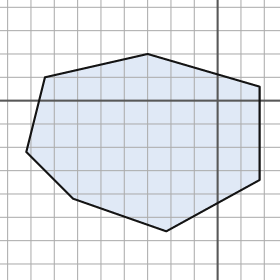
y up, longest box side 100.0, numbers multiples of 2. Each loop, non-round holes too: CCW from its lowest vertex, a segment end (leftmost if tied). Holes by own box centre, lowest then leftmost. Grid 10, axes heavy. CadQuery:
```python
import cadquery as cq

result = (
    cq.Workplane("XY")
    .moveTo(-22.0, -56.0)
    .lineTo(18.0, -34.0)
    .lineTo(18.0, 6.0)
    .lineTo(-30.0, 20.0)
    .lineTo(-74.0, 10.0)
    .lineTo(-82.0, -22.0)
    .lineTo(-62.0, -42.0)
    .close()
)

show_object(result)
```